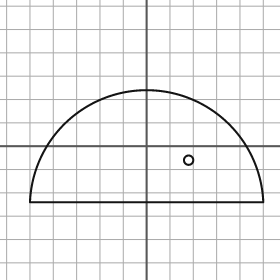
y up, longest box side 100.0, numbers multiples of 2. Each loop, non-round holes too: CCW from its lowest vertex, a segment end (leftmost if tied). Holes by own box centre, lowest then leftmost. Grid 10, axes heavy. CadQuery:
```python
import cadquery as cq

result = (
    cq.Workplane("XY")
    .moveTo(-50.0, -24.0)
    .lineTo(50.0, -24.0)
    .threePointArc((0.0, 24.0), (-50.0, -24.0))
    .close()
    .moveTo(18.0, -6.0)
    .circle(2.0)
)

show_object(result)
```